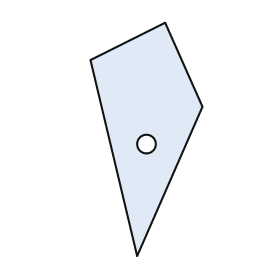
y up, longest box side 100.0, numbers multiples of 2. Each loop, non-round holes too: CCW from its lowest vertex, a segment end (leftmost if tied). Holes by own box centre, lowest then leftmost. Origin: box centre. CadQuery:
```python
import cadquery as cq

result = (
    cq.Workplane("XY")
    .moveTo(-4.0, -50.0)
    .lineTo(24.0, 14.0)
    .lineTo(8.0, 50.0)
    .lineTo(-24.0, 34.0)
    .close()
    .moveTo(0.0, -2.0)
    .circle(4.0)
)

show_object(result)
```